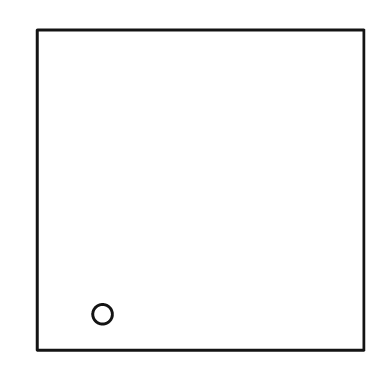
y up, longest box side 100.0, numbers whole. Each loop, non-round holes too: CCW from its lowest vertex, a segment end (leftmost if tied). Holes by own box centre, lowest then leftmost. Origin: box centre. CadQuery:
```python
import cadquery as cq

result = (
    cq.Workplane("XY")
    .moveTo(-50.0, -49.0)
    .lineTo(50.0, -49.0)
    .lineTo(50.0, 49.0)
    .lineTo(-50.0, 49.0)
    .close()
    .moveTo(-30.0, -38.0)
    .circle(3.0)
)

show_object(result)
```